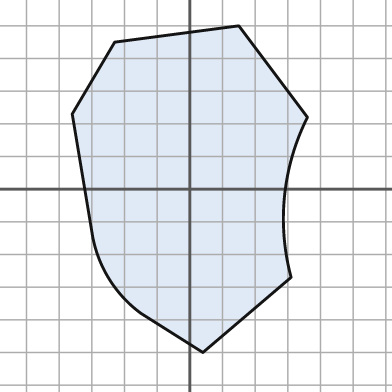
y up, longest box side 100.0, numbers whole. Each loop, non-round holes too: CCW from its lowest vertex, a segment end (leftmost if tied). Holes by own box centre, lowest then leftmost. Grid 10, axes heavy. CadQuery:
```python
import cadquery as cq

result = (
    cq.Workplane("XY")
    .moveTo(4.0, -50.0)
    .lineTo(31.0, -27.0)
    .threePointArc((29.0, -2.0), (36.0, 22.0))
    .lineTo(15.0, 50.0)
    .lineTo(-23.0, 45.0)
    .lineTo(-36.0, 23.0)
    .lineTo(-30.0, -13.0)
    .threePointArc((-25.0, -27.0), (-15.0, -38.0))
    .close()
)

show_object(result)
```